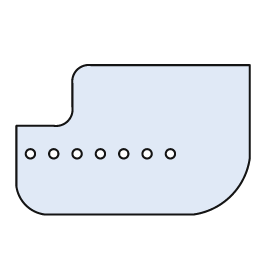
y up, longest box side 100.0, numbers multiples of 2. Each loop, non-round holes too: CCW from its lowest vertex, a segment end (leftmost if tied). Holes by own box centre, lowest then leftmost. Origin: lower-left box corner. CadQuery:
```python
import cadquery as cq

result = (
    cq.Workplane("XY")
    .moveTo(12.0, 0.0)
    .lineTo(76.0, 0.0)
    .threePointArc((92.0, 8.0), (100.0, 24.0))
    .lineTo(100.0, 64.0)
    .lineTo(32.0, 64.0)
    .threePointArc((26.0, 62.0), (24.0, 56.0))
    .lineTo(24.0, 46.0)
    .threePointArc((22.0, 40.0), (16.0, 38.0))
    .lineTo(0.0, 38.0)
    .lineTo(0.0, 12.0)
    .threePointArc((4.0, 4.0), (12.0, 0.0))
    .close()
    .moveTo(6.0, 26.0)
    .circle(2.0)
    .moveTo(16.0, 26.0)
    .circle(2.0)
    .moveTo(26.0, 26.0)
    .circle(2.0)
    .moveTo(36.0, 26.0)
    .circle(2.0)
    .moveTo(46.0, 26.0)
    .circle(2.0)
    .moveTo(56.0, 26.0)
    .circle(2.0)
    .moveTo(66.0, 26.0)
    .circle(2.0)
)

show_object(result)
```